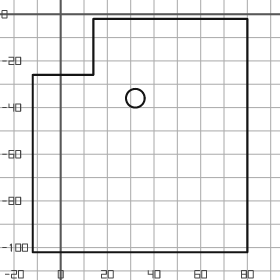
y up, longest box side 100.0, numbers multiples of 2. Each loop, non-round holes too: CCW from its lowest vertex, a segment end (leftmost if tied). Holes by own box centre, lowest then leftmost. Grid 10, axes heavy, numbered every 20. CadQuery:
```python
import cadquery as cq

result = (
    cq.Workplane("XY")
    .moveTo(-12.0, -102.0)
    .lineTo(80.0, -102.0)
    .lineTo(80.0, -2.0)
    .lineTo(14.0, -2.0)
    .lineTo(14.0, -26.0)
    .lineTo(-12.0, -26.0)
    .close()
    .moveTo(32.0, -36.0)
    .circle(4.0)
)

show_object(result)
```